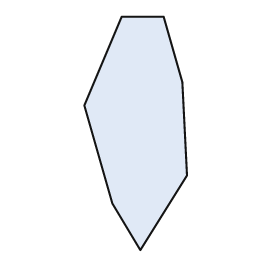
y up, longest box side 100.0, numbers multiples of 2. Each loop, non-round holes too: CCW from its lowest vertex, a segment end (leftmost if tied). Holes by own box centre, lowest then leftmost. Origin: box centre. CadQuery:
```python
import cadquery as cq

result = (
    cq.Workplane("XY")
    .moveTo(2.0, -50.0)
    .lineTo(22.0, -18.0)
    .lineTo(20.0, 22.0)
    .lineTo(12.0, 50.0)
    .lineTo(-6.0, 50.0)
    .lineTo(-22.0, 12.0)
    .lineTo(-10.0, -30.0)
    .close()
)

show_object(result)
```